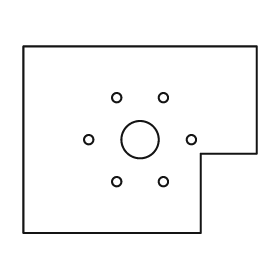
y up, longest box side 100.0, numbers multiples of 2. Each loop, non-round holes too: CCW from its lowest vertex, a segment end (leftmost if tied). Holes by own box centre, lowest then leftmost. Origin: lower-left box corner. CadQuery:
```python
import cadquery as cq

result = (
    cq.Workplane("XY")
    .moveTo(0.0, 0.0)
    .lineTo(76.0, 0.0)
    .lineTo(76.0, 34.0)
    .lineTo(100.0, 34.0)
    .lineTo(100.0, 80.0)
    .lineTo(0.0, 80.0)
    .close()
    .moveTo(40.0, 22.0)
    .circle(2.0)
    .moveTo(60.0, 22.0)
    .circle(2.0)
    .moveTo(28.0, 40.0)
    .circle(2.0)
    .moveTo(50.0, 40.0)
    .circle(8.0)
    .moveTo(72.0, 40.0)
    .circle(2.0)
    .moveTo(40.0, 58.0)
    .circle(2.0)
    .moveTo(60.0, 58.0)
    .circle(2.0)
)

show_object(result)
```